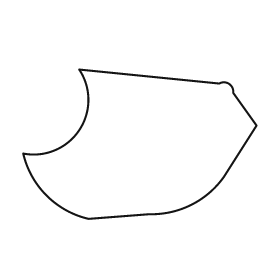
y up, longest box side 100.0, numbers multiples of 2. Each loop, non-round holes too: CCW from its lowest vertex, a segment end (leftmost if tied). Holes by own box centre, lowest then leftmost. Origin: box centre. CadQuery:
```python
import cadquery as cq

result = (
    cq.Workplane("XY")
    .moveTo(-22.0, -32.0)
    .lineTo(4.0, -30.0)
    .threePointArc((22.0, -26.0), (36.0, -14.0))
    .lineTo(50.0, 8.0)
    .lineTo(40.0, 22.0)
    .threePointArc((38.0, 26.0), (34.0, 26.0))
    .lineTo(-26.0, 32.0)
    .threePointArc((-26.0, 6.0), (-50.0, -4.0))
    .threePointArc((-40.0, -22.0), (-22.0, -32.0))
    .close()
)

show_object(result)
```